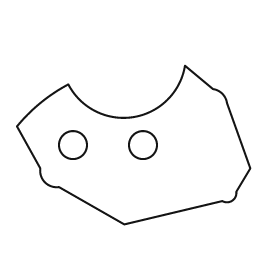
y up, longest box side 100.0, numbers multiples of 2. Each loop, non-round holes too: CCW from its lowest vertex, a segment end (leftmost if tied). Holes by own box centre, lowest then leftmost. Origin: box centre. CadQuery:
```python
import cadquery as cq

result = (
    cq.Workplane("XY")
    .moveTo(-4.0, -34.0)
    .lineTo(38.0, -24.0)
    .threePointArc((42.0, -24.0), (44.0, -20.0))
    .lineTo(50.0, -10.0)
    .lineTo(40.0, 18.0)
    .threePointArc((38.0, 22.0), (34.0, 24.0))
    .lineTo(22.0, 34.0)
    .threePointArc((0.0, 12.0), (-28.0, 26.0))
    .threePointArc((-40.0, 18.0), (-50.0, 8.0))
    .lineTo(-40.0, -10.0)
    .threePointArc((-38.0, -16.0), (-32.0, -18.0))
    .close()
    .moveTo(-26.0, 0.0)
    .circle(6.0)
    .moveTo(4.0, 0.0)
    .circle(6.0)
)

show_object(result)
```